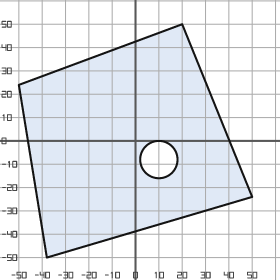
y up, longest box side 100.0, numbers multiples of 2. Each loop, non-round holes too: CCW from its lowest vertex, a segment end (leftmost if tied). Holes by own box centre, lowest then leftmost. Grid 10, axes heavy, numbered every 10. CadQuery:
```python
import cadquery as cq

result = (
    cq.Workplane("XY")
    .moveTo(-38.0, -50.0)
    .lineTo(50.0, -24.0)
    .lineTo(20.0, 50.0)
    .lineTo(-50.0, 24.0)
    .close()
    .moveTo(10.0, -8.0)
    .circle(8.0)
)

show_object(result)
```